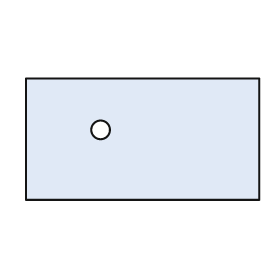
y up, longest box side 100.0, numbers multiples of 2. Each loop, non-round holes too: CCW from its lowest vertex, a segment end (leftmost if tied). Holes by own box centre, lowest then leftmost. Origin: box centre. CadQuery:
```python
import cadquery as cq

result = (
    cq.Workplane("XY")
    .moveTo(-50.0, -26.0)
    .lineTo(50.0, -26.0)
    .lineTo(50.0, 26.0)
    .lineTo(-50.0, 26.0)
    .close()
    .moveTo(-18.0, 4.0)
    .circle(4.0)
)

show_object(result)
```